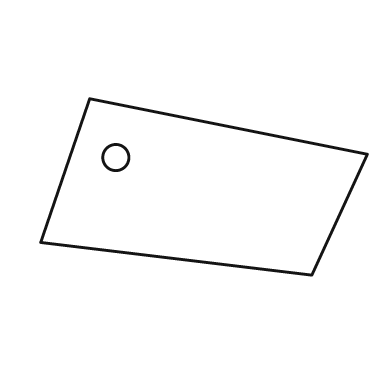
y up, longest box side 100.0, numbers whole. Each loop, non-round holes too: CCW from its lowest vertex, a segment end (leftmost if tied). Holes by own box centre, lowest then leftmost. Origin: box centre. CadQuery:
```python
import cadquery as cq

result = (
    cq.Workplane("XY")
    .moveTo(33.0, -27.0)
    .lineTo(50.0, 10.0)
    .lineTo(-35.0, 27.0)
    .lineTo(-50.0, -17.0)
    .close()
    .moveTo(-27.0, 9.0)
    .circle(4.0)
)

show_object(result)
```